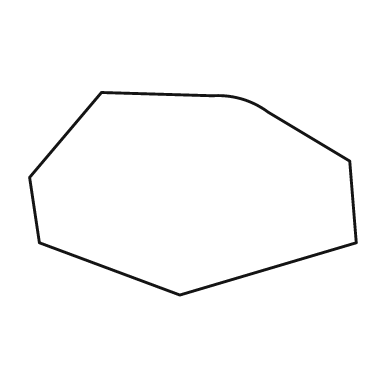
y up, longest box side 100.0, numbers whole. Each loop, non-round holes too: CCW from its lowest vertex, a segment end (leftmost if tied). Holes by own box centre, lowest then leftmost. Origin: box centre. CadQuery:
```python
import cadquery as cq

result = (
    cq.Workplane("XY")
    .moveTo(-4.0, -31.0)
    .lineTo(50.0, -15.0)
    .lineTo(48.0, 10.0)
    .lineTo(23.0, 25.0)
    .threePointArc((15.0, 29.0), (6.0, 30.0))
    .lineTo(-28.0, 31.0)
    .lineTo(-50.0, 5.0)
    .lineTo(-47.0, -15.0)
    .close()
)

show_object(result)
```